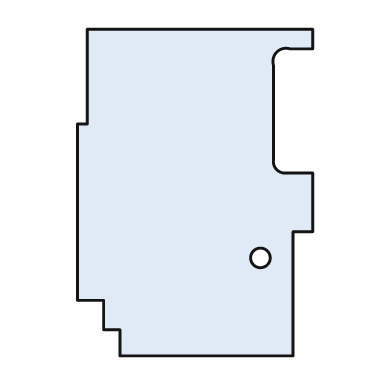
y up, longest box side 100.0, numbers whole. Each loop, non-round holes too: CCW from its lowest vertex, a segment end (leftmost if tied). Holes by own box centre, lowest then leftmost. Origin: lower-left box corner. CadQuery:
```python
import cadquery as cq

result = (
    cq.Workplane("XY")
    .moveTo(13.0, 0.0)
    .lineTo(66.0, 0.0)
    .lineTo(66.0, 38.0)
    .lineTo(72.0, 38.0)
    .lineTo(72.0, 56.0)
    .lineTo(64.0, 56.0)
    .threePointArc((61.0, 57.0), (60.0, 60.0))
    .lineTo(60.0, 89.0)
    .threePointArc((61.0, 93.0), (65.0, 94.0))
    .lineTo(72.0, 94.0)
    .lineTo(72.0, 100.0)
    .lineTo(3.0, 100.0)
    .lineTo(3.0, 71.0)
    .lineTo(0.0, 71.0)
    .lineTo(0.0, 17.0)
    .lineTo(8.0, 17.0)
    .lineTo(8.0, 8.0)
    .lineTo(13.0, 8.0)
    .close()
    .moveTo(56.0, 30.0)
    .circle(3.0)
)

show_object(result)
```